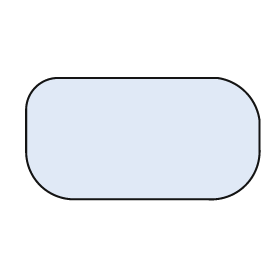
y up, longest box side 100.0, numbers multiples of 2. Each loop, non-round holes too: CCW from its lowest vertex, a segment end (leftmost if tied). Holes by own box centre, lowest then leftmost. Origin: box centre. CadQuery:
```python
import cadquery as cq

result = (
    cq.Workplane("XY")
    .moveTo(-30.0, -26.0)
    .lineTo(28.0, -26.0)
    .threePointArc((44.0, -20.0), (50.0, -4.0))
    .lineTo(50.0, 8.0)
    .threePointArc((44.0, 20.0), (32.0, 26.0))
    .lineTo(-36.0, 26.0)
    .threePointArc((-46.0, 22.0), (-50.0, 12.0))
    .lineTo(-50.0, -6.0)
    .threePointArc((-44.0, -20.0), (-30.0, -26.0))
    .close()
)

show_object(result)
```